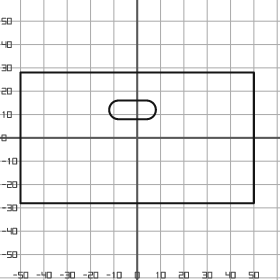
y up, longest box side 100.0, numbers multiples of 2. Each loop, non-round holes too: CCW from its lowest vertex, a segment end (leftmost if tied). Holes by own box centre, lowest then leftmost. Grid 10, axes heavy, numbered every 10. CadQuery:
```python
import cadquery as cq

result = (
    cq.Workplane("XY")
    .moveTo(-50.0, -28.0)
    .lineTo(50.0, -28.0)
    .lineTo(50.0, 28.0)
    .lineTo(-50.0, 28.0)
    .close()
    .moveTo(-8.0, 8.0)
    .lineTo(4.0, 8.0)
    .threePointArc((8.0, 12.0), (4.0, 16.0))
    .lineTo(-8.0, 16.0)
    .threePointArc((-12.0, 12.0), (-8.0, 8.0))
    .close()
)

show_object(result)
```